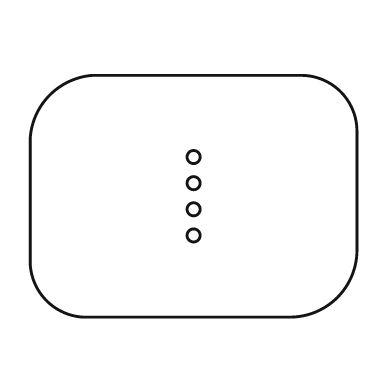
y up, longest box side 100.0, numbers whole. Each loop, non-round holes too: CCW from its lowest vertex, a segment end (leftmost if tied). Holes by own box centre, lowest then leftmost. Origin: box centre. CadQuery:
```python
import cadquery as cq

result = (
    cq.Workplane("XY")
    .moveTo(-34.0, -37.0)
    .lineTo(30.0, -37.0)
    .threePointArc((44.0, -31.0), (50.0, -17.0))
    .lineTo(50.0, 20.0)
    .threePointArc((45.0, 32.0), (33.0, 37.0))
    .lineTo(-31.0, 37.0)
    .threePointArc((-44.0, 31.0), (-50.0, 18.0))
    .lineTo(-50.0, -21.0)
    .threePointArc((-45.0, -32.0), (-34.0, -37.0))
    .close()
    .moveTo(0.0, -12.0)
    .circle(2.0)
    .moveTo(0.0, -4.0)
    .circle(2.0)
    .moveTo(0.0, 4.0)
    .circle(2.0)
    .moveTo(0.0, 12.0)
    .circle(2.0)
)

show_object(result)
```